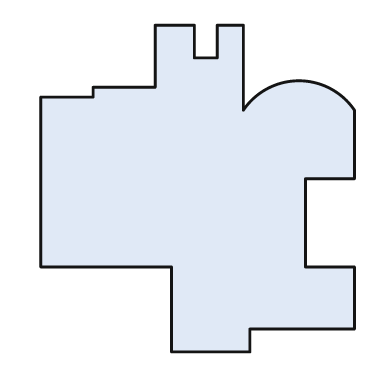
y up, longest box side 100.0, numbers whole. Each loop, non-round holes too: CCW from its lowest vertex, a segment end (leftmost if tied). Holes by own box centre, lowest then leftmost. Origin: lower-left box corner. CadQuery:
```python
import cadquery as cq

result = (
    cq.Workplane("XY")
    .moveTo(40.0, 0.0)
    .lineTo(64.0, 0.0)
    .lineTo(64.0, 7.0)
    .lineTo(96.0, 7.0)
    .lineTo(96.0, 26.0)
    .lineTo(81.0, 26.0)
    .lineTo(81.0, 53.0)
    .lineTo(96.0, 53.0)
    .lineTo(96.0, 74.0)
    .threePointArc((79.0, 83.0), (62.0, 74.0))
    .lineTo(62.0, 100.0)
    .lineTo(54.0, 100.0)
    .lineTo(54.0, 90.0)
    .lineTo(47.0, 90.0)
    .lineTo(47.0, 100.0)
    .lineTo(35.0, 100.0)
    .lineTo(35.0, 81.0)
    .lineTo(16.0, 81.0)
    .lineTo(16.0, 78.0)
    .lineTo(0.0, 78.0)
    .lineTo(0.0, 26.0)
    .lineTo(40.0, 26.0)
    .close()
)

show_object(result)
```